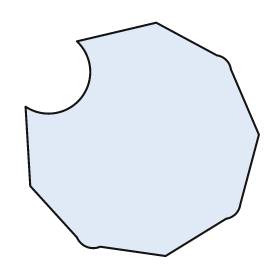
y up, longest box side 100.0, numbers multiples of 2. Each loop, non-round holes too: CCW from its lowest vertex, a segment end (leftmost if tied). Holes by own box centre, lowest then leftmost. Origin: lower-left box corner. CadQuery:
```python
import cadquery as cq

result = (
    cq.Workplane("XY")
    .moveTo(60.0, 0.0)
    .lineTo(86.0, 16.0)
    .threePointArc((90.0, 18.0), (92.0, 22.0))
    .lineTo(100.0, 52.0)
    .lineTo(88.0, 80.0)
    .threePointArc((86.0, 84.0), (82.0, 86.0))
    .lineTo(56.0, 100.0)
    .lineTo(22.0, 92.0)
    .threePointArc((24.0, 68.0), (0.0, 64.0))
    .lineTo(2.0, 30.0)
    .lineTo(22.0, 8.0)
    .threePointArc((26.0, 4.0), (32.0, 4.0))
    .close()
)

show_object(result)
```